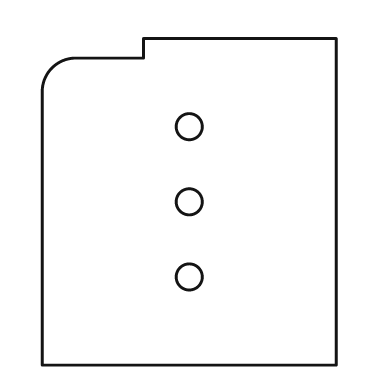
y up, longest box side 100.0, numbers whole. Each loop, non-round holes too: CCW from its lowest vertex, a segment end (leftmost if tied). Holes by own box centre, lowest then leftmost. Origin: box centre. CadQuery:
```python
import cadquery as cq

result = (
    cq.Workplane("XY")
    .moveTo(-45.0, -50.0)
    .lineTo(45.0, -50.0)
    .lineTo(45.0, 50.0)
    .lineTo(-14.0, 50.0)
    .lineTo(-14.0, 44.0)
    .lineTo(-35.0, 44.0)
    .threePointArc((-42.0, 41.0), (-45.0, 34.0))
    .close()
    .moveTo(0.0, -23.0)
    .circle(4.0)
    .moveTo(0.0, 0.0)
    .circle(4.0)
    .moveTo(0.0, 23.0)
    .circle(4.0)
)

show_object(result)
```